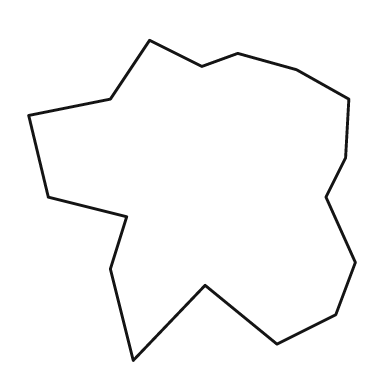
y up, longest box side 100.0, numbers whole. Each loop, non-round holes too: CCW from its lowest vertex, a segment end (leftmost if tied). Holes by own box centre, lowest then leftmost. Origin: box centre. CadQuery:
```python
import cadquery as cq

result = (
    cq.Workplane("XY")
    .moveTo(-18.0, -49.0)
    .lineTo(4.0, -26.0)
    .lineTo(26.0, -44.0)
    .lineTo(44.0, -35.0)
    .lineTo(50.0, -19.0)
    .lineTo(41.0, 1.0)
    .lineTo(47.0, 13.0)
    .lineTo(48.0, 31.0)
    .lineTo(32.0, 40.0)
    .lineTo(14.0, 45.0)
    .lineTo(3.0, 41.0)
    .lineTo(-13.0, 49.0)
    .lineTo(-25.0, 31.0)
    .lineTo(-50.0, 26.0)
    .lineTo(-44.0, 1.0)
    .lineTo(-20.0, -5.0)
    .lineTo(-25.0, -21.0)
    .close()
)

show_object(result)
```